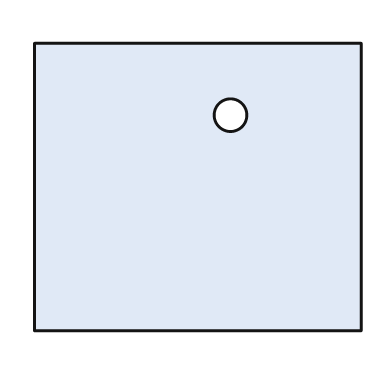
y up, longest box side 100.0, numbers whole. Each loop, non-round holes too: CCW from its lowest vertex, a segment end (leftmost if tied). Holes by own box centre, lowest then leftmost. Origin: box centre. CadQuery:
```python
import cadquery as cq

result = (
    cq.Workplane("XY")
    .moveTo(-50.0, -44.0)
    .lineTo(50.0, -44.0)
    .lineTo(50.0, 44.0)
    .lineTo(-50.0, 44.0)
    .close()
    .moveTo(10.0, 22.0)
    .circle(5.0)
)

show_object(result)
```